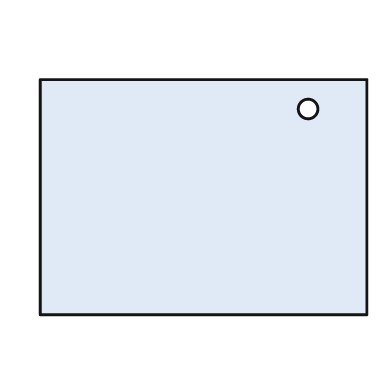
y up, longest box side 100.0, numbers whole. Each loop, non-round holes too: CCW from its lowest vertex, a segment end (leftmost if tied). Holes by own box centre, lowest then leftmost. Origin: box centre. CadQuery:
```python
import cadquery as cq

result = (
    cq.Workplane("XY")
    .moveTo(-50.0, -36.0)
    .lineTo(50.0, -36.0)
    .lineTo(50.0, 36.0)
    .lineTo(-50.0, 36.0)
    .close()
    .moveTo(32.0, 27.0)
    .circle(3.0)
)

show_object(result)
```